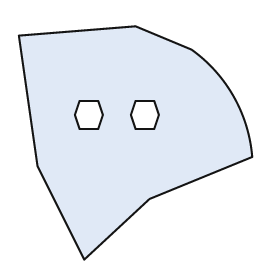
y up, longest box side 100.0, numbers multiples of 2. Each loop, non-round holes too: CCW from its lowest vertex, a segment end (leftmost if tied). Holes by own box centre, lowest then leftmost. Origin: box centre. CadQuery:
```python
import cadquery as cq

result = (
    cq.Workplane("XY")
    .moveTo(-22.0, -50.0)
    .lineTo(6.0, -24.0)
    .lineTo(50.0, -6.0)
    .threePointArc((42.0, 20.0), (24.0, 40.0))
    .lineTo(0.0, 50.0)
    .lineTo(-50.0, 46.0)
    .lineTo(-42.0, -10.0)
    .close()
    .moveTo(-24.0, 6.0)
    .lineTo(-16.0, 6.0)
    .lineTo(-14.0, 12.0)
    .lineTo(-16.0, 18.0)
    .lineTo(-24.0, 18.0)
    .lineTo(-26.0, 12.0)
    .close()
    .moveTo(0.0, 6.0)
    .lineTo(8.0, 6.0)
    .lineTo(10.0, 12.0)
    .lineTo(8.0, 18.0)
    .lineTo(0.0, 18.0)
    .lineTo(-2.0, 12.0)
    .close()
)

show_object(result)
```